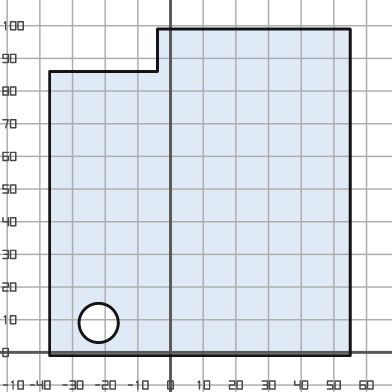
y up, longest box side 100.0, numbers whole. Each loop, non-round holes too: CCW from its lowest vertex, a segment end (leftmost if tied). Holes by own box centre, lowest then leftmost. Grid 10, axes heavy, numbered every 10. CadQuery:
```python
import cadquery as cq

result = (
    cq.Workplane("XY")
    .moveTo(-37.0, -1.0)
    .lineTo(55.0, -1.0)
    .lineTo(55.0, 99.0)
    .lineTo(-4.0, 99.0)
    .lineTo(-4.0, 86.0)
    .lineTo(-37.0, 86.0)
    .close()
    .moveTo(-22.0, 9.0)
    .circle(6.0)
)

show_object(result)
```